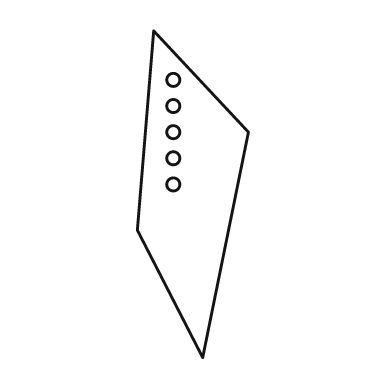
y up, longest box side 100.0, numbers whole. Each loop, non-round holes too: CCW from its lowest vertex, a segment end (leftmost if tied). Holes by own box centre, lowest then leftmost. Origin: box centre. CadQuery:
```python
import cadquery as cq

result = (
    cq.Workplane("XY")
    .moveTo(3.0, -50.0)
    .lineTo(17.0, 19.0)
    .lineTo(-12.0, 50.0)
    .lineTo(-17.0, -11.0)
    .close()
    .moveTo(-6.0, 3.0)
    .circle(2.0)
    .moveTo(-6.0, 11.0)
    .circle(2.0)
    .moveTo(-6.0, 19.0)
    .circle(2.0)
    .moveTo(-6.0, 27.0)
    .circle(2.0)
    .moveTo(-6.0, 35.0)
    .circle(2.0)
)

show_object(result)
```